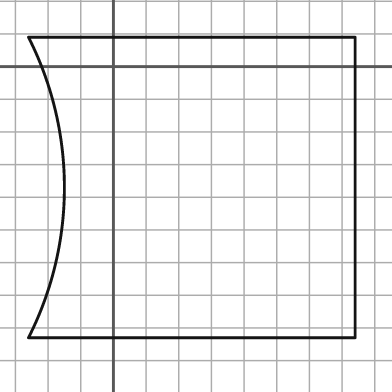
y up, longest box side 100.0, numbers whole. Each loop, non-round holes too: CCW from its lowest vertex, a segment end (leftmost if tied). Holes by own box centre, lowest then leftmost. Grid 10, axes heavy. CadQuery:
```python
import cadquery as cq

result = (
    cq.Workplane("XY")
    .moveTo(-26.0, -83.0)
    .lineTo(74.0, -83.0)
    .lineTo(74.0, 9.0)
    .lineTo(-26.0, 9.0)
    .threePointArc((-15.0, -37.0), (-26.0, -83.0))
    .close()
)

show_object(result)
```